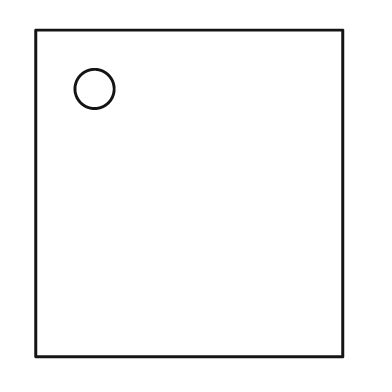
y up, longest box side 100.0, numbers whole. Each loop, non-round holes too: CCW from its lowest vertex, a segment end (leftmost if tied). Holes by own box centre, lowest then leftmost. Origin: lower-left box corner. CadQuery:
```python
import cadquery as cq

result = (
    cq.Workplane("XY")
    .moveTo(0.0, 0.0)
    .lineTo(94.0, 0.0)
    .lineTo(94.0, 100.0)
    .lineTo(0.0, 100.0)
    .close()
    .moveTo(18.0, 82.0)
    .circle(6.0)
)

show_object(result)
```